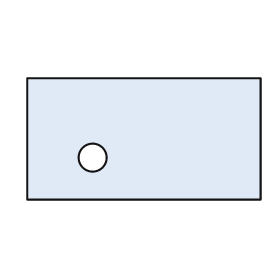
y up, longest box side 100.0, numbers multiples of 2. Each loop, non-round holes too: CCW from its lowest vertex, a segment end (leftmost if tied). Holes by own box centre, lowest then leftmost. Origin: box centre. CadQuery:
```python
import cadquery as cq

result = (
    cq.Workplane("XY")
    .moveTo(-50.0, -26.0)
    .lineTo(50.0, -26.0)
    .lineTo(50.0, 26.0)
    .lineTo(-50.0, 26.0)
    .close()
    .moveTo(-22.0, -8.0)
    .circle(6.0)
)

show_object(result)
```